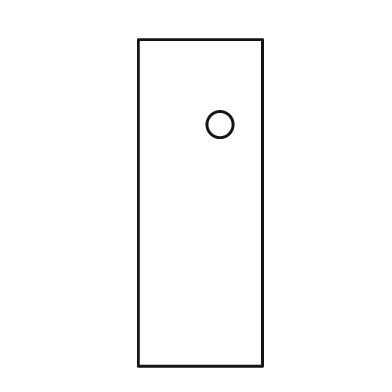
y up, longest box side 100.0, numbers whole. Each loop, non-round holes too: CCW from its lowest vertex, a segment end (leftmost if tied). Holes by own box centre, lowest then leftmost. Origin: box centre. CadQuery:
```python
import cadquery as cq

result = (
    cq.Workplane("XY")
    .moveTo(-19.0, -50.0)
    .lineTo(19.0, -50.0)
    .lineTo(19.0, 50.0)
    .lineTo(-19.0, 50.0)
    .close()
    .moveTo(6.0, 24.0)
    .circle(4.0)
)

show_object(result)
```